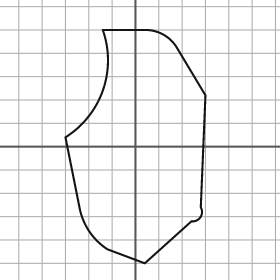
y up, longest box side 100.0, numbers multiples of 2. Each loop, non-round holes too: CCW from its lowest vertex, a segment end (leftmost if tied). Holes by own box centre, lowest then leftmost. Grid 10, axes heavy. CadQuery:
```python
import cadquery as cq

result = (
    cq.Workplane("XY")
    .moveTo(4.0, -50.0)
    .lineTo(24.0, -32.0)
    .threePointArc((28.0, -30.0), (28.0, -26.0))
    .lineTo(30.0, 22.0)
    .lineTo(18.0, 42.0)
    .threePointArc((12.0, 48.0), (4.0, 50.0))
    .lineTo(-14.0, 50.0)
    .threePointArc((-14.0, 24.0), (-30.0, 4.0))
    .lineTo(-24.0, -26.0)
    .threePointArc((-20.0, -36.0), (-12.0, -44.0))
    .close()
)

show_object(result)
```